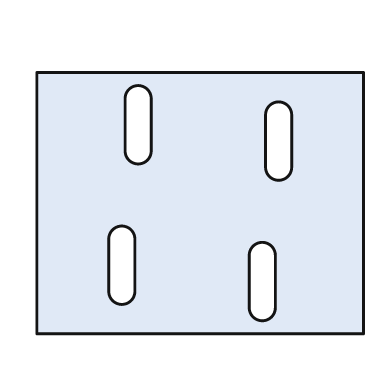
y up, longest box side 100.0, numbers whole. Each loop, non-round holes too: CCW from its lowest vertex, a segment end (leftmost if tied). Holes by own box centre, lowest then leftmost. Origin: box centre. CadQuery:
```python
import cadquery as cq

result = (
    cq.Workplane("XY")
    .moveTo(-50.0, -40.0)
    .lineTo(50.0, -40.0)
    .lineTo(50.0, 40.0)
    .lineTo(-50.0, 40.0)
    .close()
    .moveTo(15.0, -32.0)
    .threePointArc((19.0, -36.0), (23.0, -32.0))
    .lineTo(23.0, -16.0)
    .threePointArc((19.0, -12.0), (15.0, -16.0))
    .close()
    .moveTo(-28.0, -27.0)
    .threePointArc((-24.0, -31.0), (-20.0, -27.0))
    .lineTo(-20.0, -11.0)
    .threePointArc((-24.0, -7.0), (-28.0, -11.0))
    .close()
    .moveTo(20.0, 11.0)
    .threePointArc((24.0, 7.0), (28.0, 11.0))
    .lineTo(28.0, 27.0)
    .threePointArc((24.0, 31.0), (20.0, 27.0))
    .close()
    .moveTo(-23.0, 16.0)
    .threePointArc((-19.0, 12.0), (-15.0, 16.0))
    .lineTo(-15.0, 32.0)
    .threePointArc((-19.0, 36.0), (-23.0, 32.0))
    .close()
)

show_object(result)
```